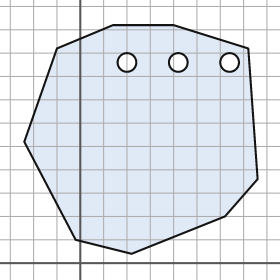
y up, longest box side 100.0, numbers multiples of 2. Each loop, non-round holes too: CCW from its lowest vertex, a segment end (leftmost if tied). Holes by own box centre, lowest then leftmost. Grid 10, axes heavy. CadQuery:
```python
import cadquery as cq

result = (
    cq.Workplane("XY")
    .moveTo(22.0, 4.0)
    .lineTo(62.0, 20.0)
    .lineTo(76.0, 36.0)
    .lineTo(72.0, 92.0)
    .lineTo(40.0, 102.0)
    .lineTo(14.0, 102.0)
    .lineTo(-10.0, 92.0)
    .lineTo(-24.0, 52.0)
    .lineTo(-2.0, 10.0)
    .close()
    .moveTo(20.0, 86.0)
    .circle(4.0)
    .moveTo(42.0, 86.0)
    .circle(4.0)
    .moveTo(64.0, 86.0)
    .circle(4.0)
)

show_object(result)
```